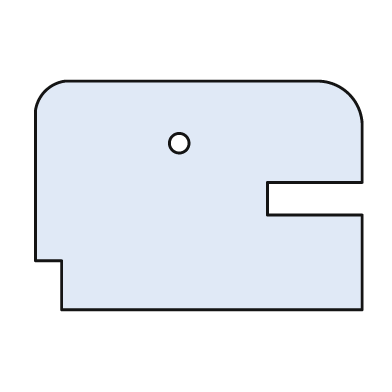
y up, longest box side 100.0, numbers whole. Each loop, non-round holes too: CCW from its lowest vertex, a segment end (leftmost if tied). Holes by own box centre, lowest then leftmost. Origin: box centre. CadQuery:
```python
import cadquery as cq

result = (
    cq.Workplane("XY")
    .moveTo(-42.0, -35.0)
    .lineTo(50.0, -35.0)
    .lineTo(50.0, -6.0)
    .lineTo(21.0, -6.0)
    .lineTo(21.0, 4.0)
    .lineTo(50.0, 4.0)
    .lineTo(50.0, 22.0)
    .threePointArc((46.0, 31.0), (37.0, 35.0))
    .lineTo(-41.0, 35.0)
    .threePointArc((-47.0, 32.0), (-50.0, 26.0))
    .lineTo(-50.0, -20.0)
    .lineTo(-42.0, -20.0)
    .close()
    .moveTo(-6.0, 16.0)
    .circle(3.0)
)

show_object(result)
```